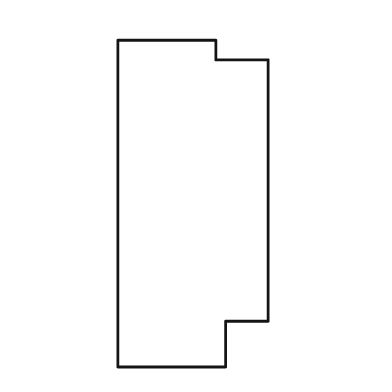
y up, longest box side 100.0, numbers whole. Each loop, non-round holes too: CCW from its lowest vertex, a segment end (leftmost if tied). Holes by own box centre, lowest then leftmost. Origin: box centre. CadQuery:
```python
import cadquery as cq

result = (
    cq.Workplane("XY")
    .moveTo(-23.0, -50.0)
    .lineTo(10.0, -50.0)
    .lineTo(10.0, -36.0)
    .lineTo(23.0, -36.0)
    .lineTo(23.0, 44.0)
    .lineTo(7.0, 44.0)
    .lineTo(7.0, 50.0)
    .lineTo(-23.0, 50.0)
    .close()
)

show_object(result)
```